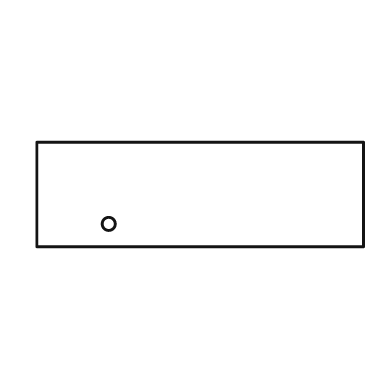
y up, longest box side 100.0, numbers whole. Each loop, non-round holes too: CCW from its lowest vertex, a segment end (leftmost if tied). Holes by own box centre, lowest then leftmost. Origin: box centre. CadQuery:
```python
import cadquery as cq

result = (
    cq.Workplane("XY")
    .moveTo(-50.0, -16.0)
    .lineTo(50.0, -16.0)
    .lineTo(50.0, 16.0)
    .lineTo(-50.0, 16.0)
    .close()
    .moveTo(-28.0, -9.0)
    .circle(2.0)
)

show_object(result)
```